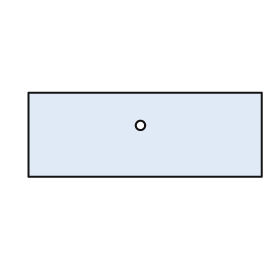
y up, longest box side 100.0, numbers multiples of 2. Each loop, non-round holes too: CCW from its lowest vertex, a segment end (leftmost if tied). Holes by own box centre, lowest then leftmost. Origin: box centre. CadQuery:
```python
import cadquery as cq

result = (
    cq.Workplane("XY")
    .moveTo(-50.0, -18.0)
    .lineTo(50.0, -18.0)
    .lineTo(50.0, 18.0)
    .lineTo(-50.0, 18.0)
    .close()
    .moveTo(-2.0, 4.0)
    .circle(2.0)
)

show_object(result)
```